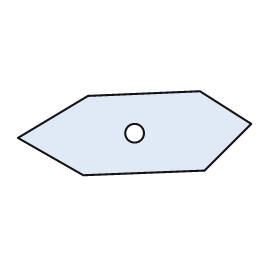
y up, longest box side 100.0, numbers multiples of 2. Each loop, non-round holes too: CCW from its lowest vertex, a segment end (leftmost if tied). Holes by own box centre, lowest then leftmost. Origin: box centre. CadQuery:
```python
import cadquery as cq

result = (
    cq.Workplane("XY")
    .moveTo(-22.0, -18.0)
    .lineTo(30.0, -16.0)
    .lineTo(50.0, 4.0)
    .lineTo(28.0, 18.0)
    .lineTo(-20.0, 16.0)
    .lineTo(-50.0, -2.0)
    .close()
    .moveTo(0.0, 0.0)
    .circle(4.0)
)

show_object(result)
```